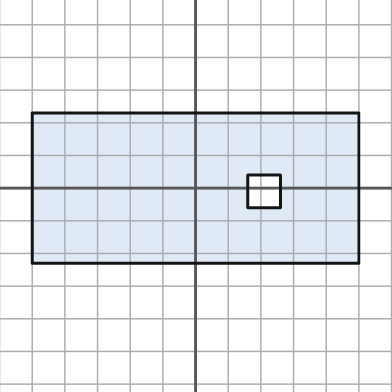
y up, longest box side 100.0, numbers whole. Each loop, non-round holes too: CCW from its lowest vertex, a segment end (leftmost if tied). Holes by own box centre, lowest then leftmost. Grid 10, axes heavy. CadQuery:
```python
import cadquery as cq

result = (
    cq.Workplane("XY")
    .moveTo(-50.0, -23.0)
    .lineTo(50.0, -23.0)
    .lineTo(50.0, 23.0)
    .lineTo(-50.0, 23.0)
    .close()
    .moveTo(16.0, -6.0)
    .lineTo(26.0, -6.0)
    .lineTo(26.0, 4.0)
    .lineTo(16.0, 4.0)
    .close()
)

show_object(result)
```